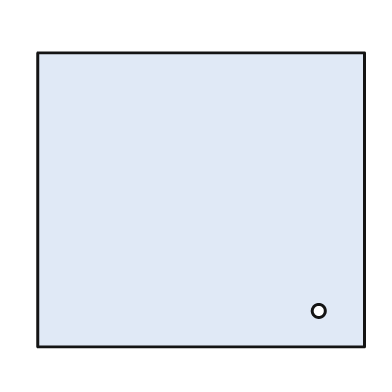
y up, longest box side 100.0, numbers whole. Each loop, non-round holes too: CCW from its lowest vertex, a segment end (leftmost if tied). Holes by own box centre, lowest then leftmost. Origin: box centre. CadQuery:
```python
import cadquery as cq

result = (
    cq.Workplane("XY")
    .moveTo(-50.0, -45.0)
    .lineTo(50.0, -45.0)
    .lineTo(50.0, 45.0)
    .lineTo(-50.0, 45.0)
    .close()
    .moveTo(36.0, -34.0)
    .circle(2.0)
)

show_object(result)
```